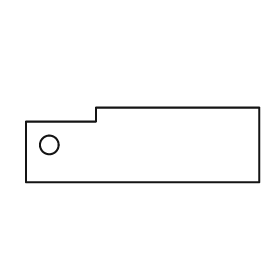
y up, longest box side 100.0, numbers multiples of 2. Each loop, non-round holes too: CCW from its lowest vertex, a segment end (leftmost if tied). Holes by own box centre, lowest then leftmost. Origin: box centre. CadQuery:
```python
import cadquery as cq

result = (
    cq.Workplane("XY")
    .moveTo(-50.0, -16.0)
    .lineTo(50.0, -16.0)
    .lineTo(50.0, 16.0)
    .lineTo(-20.0, 16.0)
    .lineTo(-20.0, 10.0)
    .lineTo(-50.0, 10.0)
    .close()
    .moveTo(-40.0, 0.0)
    .circle(4.0)
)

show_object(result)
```